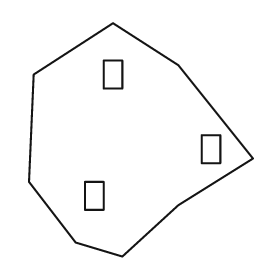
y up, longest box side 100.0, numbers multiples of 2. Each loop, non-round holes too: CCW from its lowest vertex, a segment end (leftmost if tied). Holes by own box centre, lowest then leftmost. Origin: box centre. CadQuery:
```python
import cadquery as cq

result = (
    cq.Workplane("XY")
    .moveTo(-8.0, -50.0)
    .lineTo(16.0, -28.0)
    .lineTo(48.0, -8.0)
    .lineTo(16.0, 32.0)
    .lineTo(-12.0, 50.0)
    .lineTo(-46.0, 28.0)
    .lineTo(-48.0, -18.0)
    .lineTo(-28.0, -44.0)
    .close()
    .moveTo(-24.0, -30.0)
    .lineTo(-16.0, -30.0)
    .lineTo(-16.0, -18.0)
    .lineTo(-24.0, -18.0)
    .close()
    .moveTo(26.0, -10.0)
    .lineTo(34.0, -10.0)
    .lineTo(34.0, 2.0)
    .lineTo(26.0, 2.0)
    .close()
    .moveTo(-16.0, 22.0)
    .lineTo(-8.0, 22.0)
    .lineTo(-8.0, 34.0)
    .lineTo(-16.0, 34.0)
    .close()
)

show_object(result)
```